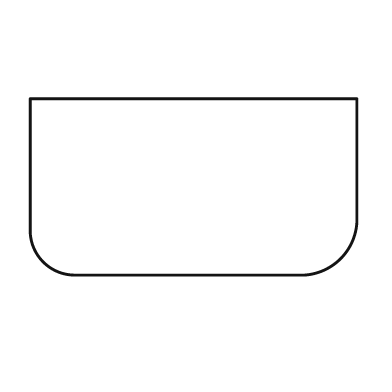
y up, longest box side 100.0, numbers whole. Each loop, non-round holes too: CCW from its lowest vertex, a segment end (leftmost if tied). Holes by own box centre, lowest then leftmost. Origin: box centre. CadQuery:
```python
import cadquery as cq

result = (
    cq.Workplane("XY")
    .moveTo(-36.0, -27.0)
    .lineTo(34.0, -27.0)
    .threePointArc((45.0, -22.0), (50.0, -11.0))
    .lineTo(50.0, 27.0)
    .lineTo(-50.0, 27.0)
    .lineTo(-50.0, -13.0)
    .threePointArc((-46.0, -23.0), (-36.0, -27.0))
    .close()
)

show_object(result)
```